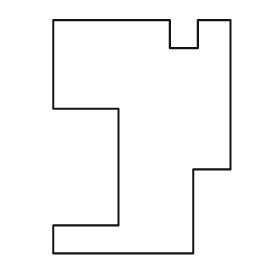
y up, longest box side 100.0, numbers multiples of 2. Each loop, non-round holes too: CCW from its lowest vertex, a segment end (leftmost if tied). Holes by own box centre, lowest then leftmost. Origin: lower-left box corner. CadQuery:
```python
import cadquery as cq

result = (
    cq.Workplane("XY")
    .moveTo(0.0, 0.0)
    .lineTo(60.0, 0.0)
    .lineTo(60.0, 36.0)
    .lineTo(76.0, 36.0)
    .lineTo(76.0, 100.0)
    .lineTo(62.0, 100.0)
    .lineTo(62.0, 88.0)
    .lineTo(50.0, 88.0)
    .lineTo(50.0, 100.0)
    .lineTo(0.0, 100.0)
    .lineTo(0.0, 62.0)
    .lineTo(28.0, 62.0)
    .lineTo(28.0, 12.0)
    .lineTo(0.0, 12.0)
    .close()
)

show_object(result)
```